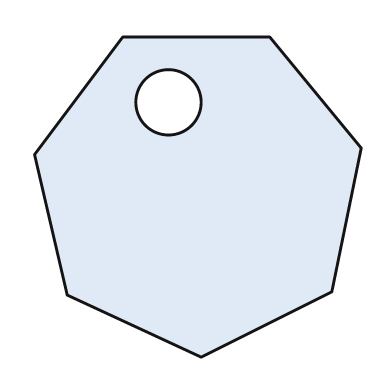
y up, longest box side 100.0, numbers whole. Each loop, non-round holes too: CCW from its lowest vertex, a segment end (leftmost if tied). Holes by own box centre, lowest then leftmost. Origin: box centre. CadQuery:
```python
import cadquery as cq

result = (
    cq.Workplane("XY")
    .moveTo(1.0, -49.0)
    .lineTo(41.0, -29.0)
    .lineTo(50.0, 15.0)
    .lineTo(22.0, 49.0)
    .lineTo(-23.0, 49.0)
    .lineTo(-50.0, 13.0)
    .lineTo(-40.0, -30.0)
    .close()
    .moveTo(-9.0, 29.0)
    .circle(10.0)
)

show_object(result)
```